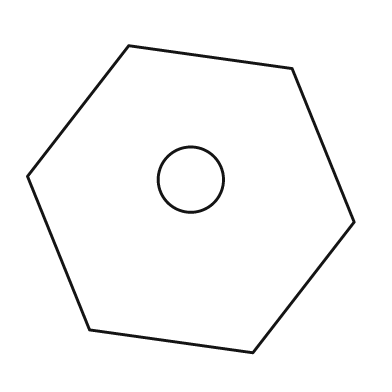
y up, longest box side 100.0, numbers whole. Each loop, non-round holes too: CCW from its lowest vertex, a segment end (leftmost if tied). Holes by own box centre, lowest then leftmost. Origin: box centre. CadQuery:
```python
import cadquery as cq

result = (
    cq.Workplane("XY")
    .moveTo(19.0, -47.0)
    .lineTo(50.0, -7.0)
    .lineTo(31.0, 40.0)
    .lineTo(-19.0, 47.0)
    .lineTo(-50.0, 7.0)
    .lineTo(-31.0, -40.0)
    .close()
    .moveTo(0.0, 6.0)
    .circle(10.0)
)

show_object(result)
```